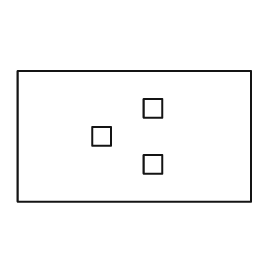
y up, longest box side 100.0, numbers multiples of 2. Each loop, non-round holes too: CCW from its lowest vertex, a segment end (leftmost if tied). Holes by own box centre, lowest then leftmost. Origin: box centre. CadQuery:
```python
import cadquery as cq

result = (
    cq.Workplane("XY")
    .moveTo(-50.0, -28.0)
    .lineTo(50.0, -28.0)
    .lineTo(50.0, 28.0)
    .lineTo(-50.0, 28.0)
    .close()
    .moveTo(4.0, -16.0)
    .lineTo(12.0, -16.0)
    .lineTo(12.0, -8.0)
    .lineTo(4.0, -8.0)
    .close()
    .moveTo(-18.0, -4.0)
    .lineTo(-10.0, -4.0)
    .lineTo(-10.0, 4.0)
    .lineTo(-18.0, 4.0)
    .close()
    .moveTo(4.0, 8.0)
    .lineTo(12.0, 8.0)
    .lineTo(12.0, 16.0)
    .lineTo(4.0, 16.0)
    .close()
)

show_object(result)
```